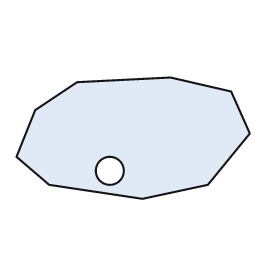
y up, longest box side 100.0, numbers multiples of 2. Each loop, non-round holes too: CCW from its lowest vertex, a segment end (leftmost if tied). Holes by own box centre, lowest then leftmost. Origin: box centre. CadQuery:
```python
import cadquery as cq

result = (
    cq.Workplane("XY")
    .moveTo(4.0, -26.0)
    .lineTo(32.0, -20.0)
    .lineTo(50.0, 2.0)
    .lineTo(42.0, 20.0)
    .lineTo(16.0, 26.0)
    .lineTo(-24.0, 24.0)
    .lineTo(-42.0, 12.0)
    .lineTo(-50.0, -8.0)
    .lineTo(-36.0, -20.0)
    .close()
    .moveTo(-10.0, -14.0)
    .circle(6.0)
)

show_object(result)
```